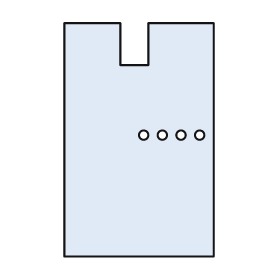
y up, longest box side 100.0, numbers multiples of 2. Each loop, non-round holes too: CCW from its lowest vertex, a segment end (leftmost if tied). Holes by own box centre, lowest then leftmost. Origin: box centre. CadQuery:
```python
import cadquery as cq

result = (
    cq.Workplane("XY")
    .moveTo(-32.0, -50.0)
    .lineTo(32.0, -50.0)
    .lineTo(32.0, 50.0)
    .lineTo(4.0, 50.0)
    .lineTo(4.0, 32.0)
    .lineTo(-8.0, 32.0)
    .lineTo(-8.0, 50.0)
    .lineTo(-32.0, 50.0)
    .close()
    .moveTo(2.0, 2.0)
    .circle(2.0)
    .moveTo(10.0, 2.0)
    .circle(2.0)
    .moveTo(18.0, 2.0)
    .circle(2.0)
    .moveTo(26.0, 2.0)
    .circle(2.0)
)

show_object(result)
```